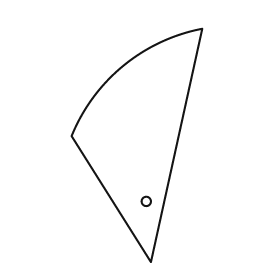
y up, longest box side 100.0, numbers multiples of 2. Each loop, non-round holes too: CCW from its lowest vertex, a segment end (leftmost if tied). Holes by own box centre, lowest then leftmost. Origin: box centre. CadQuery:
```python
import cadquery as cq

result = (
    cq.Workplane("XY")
    .moveTo(6.0, -50.0)
    .lineTo(28.0, 50.0)
    .threePointArc((-6.0, 34.0), (-28.0, 4.0))
    .close()
    .moveTo(4.0, -24.0)
    .circle(2.0)
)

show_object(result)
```